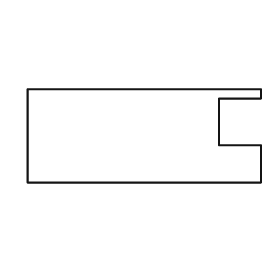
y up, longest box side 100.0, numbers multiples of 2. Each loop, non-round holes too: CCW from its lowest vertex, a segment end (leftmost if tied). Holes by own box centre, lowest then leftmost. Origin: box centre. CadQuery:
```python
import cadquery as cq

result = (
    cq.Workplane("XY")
    .moveTo(-50.0, -20.0)
    .lineTo(50.0, -20.0)
    .lineTo(50.0, -4.0)
    .lineTo(32.0, -4.0)
    .lineTo(32.0, 16.0)
    .lineTo(50.0, 16.0)
    .lineTo(50.0, 20.0)
    .lineTo(-50.0, 20.0)
    .close()
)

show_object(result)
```